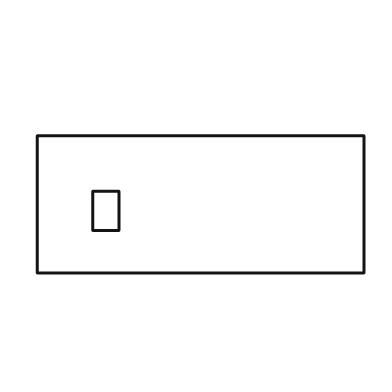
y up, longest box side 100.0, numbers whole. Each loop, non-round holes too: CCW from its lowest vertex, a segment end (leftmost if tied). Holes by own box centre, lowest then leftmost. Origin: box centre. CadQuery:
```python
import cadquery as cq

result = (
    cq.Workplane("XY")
    .moveTo(-50.0, -21.0)
    .lineTo(50.0, -21.0)
    .lineTo(50.0, 21.0)
    .lineTo(-50.0, 21.0)
    .close()
    .moveTo(-33.0, -8.0)
    .lineTo(-25.0, -8.0)
    .lineTo(-25.0, 4.0)
    .lineTo(-33.0, 4.0)
    .close()
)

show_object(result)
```